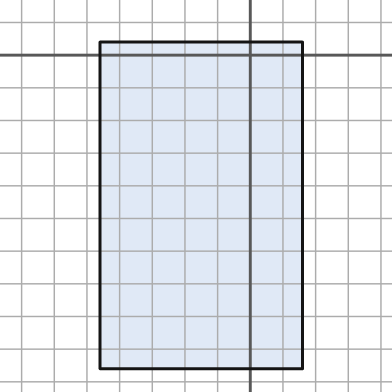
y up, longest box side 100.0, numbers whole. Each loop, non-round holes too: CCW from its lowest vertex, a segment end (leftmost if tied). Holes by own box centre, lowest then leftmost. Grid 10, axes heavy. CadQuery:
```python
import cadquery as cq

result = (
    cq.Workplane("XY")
    .moveTo(-46.0, -96.0)
    .lineTo(16.0, -96.0)
    .lineTo(16.0, 4.0)
    .lineTo(-46.0, 4.0)
    .close()
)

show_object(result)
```